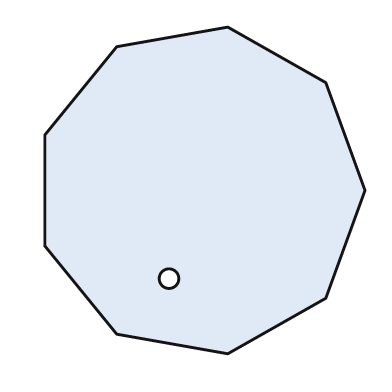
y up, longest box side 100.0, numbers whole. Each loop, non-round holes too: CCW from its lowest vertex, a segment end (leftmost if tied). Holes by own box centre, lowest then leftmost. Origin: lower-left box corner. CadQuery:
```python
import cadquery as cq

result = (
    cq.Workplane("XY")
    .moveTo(56.0, 0.0)
    .lineTo(86.0, 17.0)
    .lineTo(98.0, 50.0)
    .lineTo(86.0, 83.0)
    .lineTo(56.0, 100.0)
    .lineTo(22.0, 94.0)
    .lineTo(0.0, 67.0)
    .lineTo(0.0, 33.0)
    .lineTo(22.0, 6.0)
    .close()
    .moveTo(38.0, 23.0)
    .circle(3.0)
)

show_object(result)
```